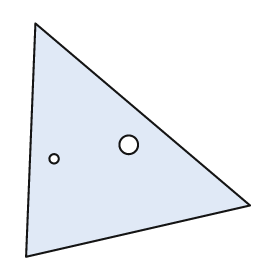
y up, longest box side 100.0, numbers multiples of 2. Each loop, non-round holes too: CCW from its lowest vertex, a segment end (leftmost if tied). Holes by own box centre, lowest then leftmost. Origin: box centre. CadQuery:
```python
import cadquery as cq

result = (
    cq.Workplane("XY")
    .moveTo(-48.0, -50.0)
    .lineTo(48.0, -28.0)
    .lineTo(-44.0, 50.0)
    .close()
    .moveTo(-36.0, -8.0)
    .circle(2.0)
    .moveTo(-4.0, -2.0)
    .circle(4.0)
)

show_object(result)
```